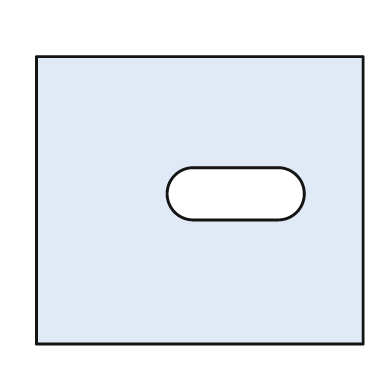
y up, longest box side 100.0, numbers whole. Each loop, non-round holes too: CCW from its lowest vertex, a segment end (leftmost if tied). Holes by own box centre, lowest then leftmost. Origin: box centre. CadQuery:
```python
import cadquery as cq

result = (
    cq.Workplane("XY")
    .moveTo(-50.0, -44.0)
    .lineTo(50.0, -44.0)
    .lineTo(50.0, 44.0)
    .lineTo(-50.0, 44.0)
    .close()
    .moveTo(-2.0, -6.0)
    .lineTo(24.0, -6.0)
    .threePointArc((32.0, 2.0), (24.0, 10.0))
    .lineTo(-2.0, 10.0)
    .threePointArc((-10.0, 2.0), (-2.0, -6.0))
    .close()
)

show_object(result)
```